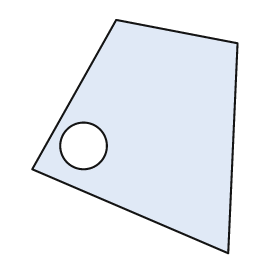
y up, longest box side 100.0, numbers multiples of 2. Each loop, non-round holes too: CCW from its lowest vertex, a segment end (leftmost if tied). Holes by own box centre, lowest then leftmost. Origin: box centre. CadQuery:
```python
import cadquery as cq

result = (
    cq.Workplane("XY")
    .moveTo(40.0, -50.0)
    .lineTo(44.0, 40.0)
    .lineTo(-8.0, 50.0)
    .lineTo(-44.0, -14.0)
    .close()
    .moveTo(-22.0, -4.0)
    .circle(10.0)
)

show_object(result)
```